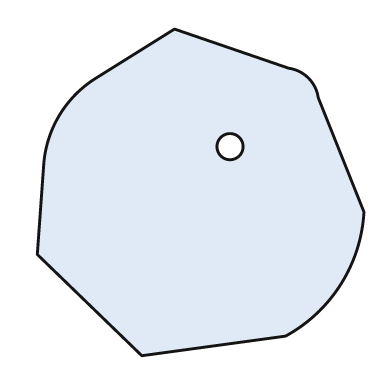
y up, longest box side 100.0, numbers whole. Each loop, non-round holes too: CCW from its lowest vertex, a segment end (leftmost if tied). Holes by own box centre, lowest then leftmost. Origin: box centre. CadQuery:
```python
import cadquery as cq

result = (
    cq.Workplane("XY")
    .moveTo(-18.0, -50.0)
    .lineTo(26.0, -44.0)
    .threePointArc((43.0, -28.0), (50.0, -6.0))
    .lineTo(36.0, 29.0)
    .threePointArc((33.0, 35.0), (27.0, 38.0))
    .lineTo(-8.0, 50.0)
    .lineTo(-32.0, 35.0)
    .threePointArc((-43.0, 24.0), (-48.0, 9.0))
    .lineTo(-50.0, -19.0)
    .close()
    .moveTo(9.0, 14.0)
    .circle(4.0)
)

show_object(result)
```